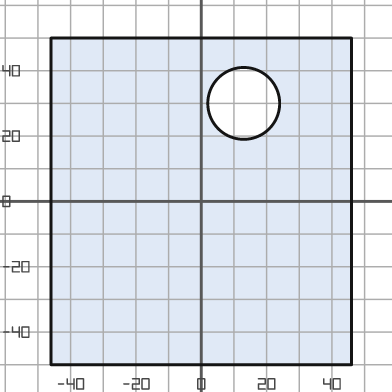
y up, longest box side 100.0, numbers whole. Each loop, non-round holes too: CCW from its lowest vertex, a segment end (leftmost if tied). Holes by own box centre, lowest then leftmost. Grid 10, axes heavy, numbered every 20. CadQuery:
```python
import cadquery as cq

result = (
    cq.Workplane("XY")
    .moveTo(-46.0, -50.0)
    .lineTo(46.0, -50.0)
    .lineTo(46.0, 50.0)
    .lineTo(-46.0, 50.0)
    .close()
    .moveTo(13.0, 30.0)
    .circle(11.0)
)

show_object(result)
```